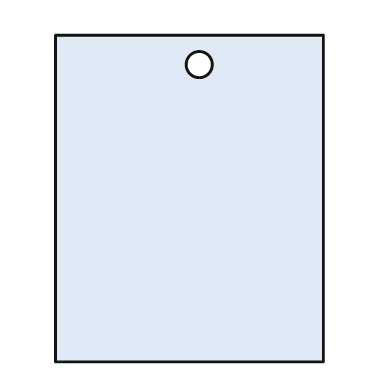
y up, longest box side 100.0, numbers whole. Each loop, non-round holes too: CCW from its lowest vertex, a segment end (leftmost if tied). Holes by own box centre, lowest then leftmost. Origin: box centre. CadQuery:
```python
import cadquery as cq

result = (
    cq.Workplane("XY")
    .moveTo(-41.0, -50.0)
    .lineTo(41.0, -50.0)
    .lineTo(41.0, 50.0)
    .lineTo(-41.0, 50.0)
    .close()
    .moveTo(3.0, 41.0)
    .circle(4.0)
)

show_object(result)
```